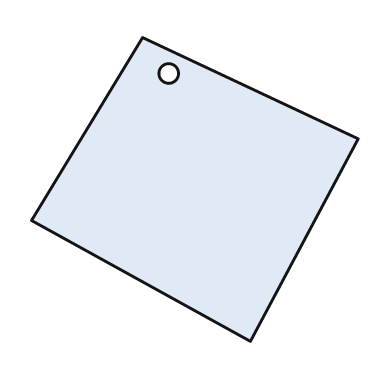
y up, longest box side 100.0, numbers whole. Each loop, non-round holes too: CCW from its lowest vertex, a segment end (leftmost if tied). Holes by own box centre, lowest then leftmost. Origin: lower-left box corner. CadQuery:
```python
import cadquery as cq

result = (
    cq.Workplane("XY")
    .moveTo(67.0, 0.0)
    .lineTo(100.0, 62.0)
    .lineTo(34.0, 93.0)
    .lineTo(0.0, 37.0)
    .close()
    .moveTo(42.0, 82.0)
    .circle(3.0)
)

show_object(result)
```